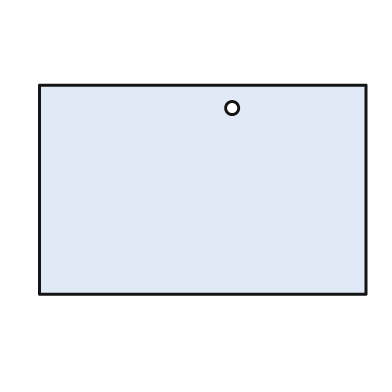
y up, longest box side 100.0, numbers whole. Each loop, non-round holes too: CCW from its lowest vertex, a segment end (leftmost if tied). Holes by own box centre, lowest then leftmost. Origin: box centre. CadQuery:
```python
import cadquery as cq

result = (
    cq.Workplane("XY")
    .moveTo(-50.0, -32.0)
    .lineTo(50.0, -32.0)
    .lineTo(50.0, 32.0)
    .lineTo(-50.0, 32.0)
    .close()
    .moveTo(9.0, 25.0)
    .circle(2.0)
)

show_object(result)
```